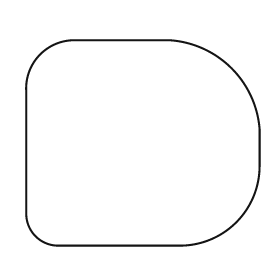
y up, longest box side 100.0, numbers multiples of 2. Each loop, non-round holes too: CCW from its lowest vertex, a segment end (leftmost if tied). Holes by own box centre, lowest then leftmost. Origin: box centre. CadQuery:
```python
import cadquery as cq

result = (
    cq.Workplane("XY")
    .moveTo(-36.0, -44.0)
    .lineTo(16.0, -44.0)
    .threePointArc((40.0, -34.0), (50.0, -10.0))
    .lineTo(50.0, 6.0)
    .threePointArc((38.0, 32.0), (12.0, 44.0))
    .lineTo(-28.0, 44.0)
    .threePointArc((-44.0, 38.0), (-50.0, 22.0))
    .lineTo(-50.0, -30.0)
    .threePointArc((-46.0, -40.0), (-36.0, -44.0))
    .close()
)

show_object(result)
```